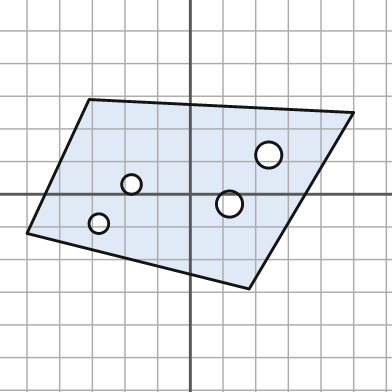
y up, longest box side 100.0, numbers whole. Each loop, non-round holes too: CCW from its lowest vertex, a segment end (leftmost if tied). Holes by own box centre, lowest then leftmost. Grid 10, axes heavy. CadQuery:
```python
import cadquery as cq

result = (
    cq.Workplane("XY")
    .moveTo(18.0, -29.0)
    .lineTo(50.0, 25.0)
    .lineTo(-31.0, 29.0)
    .lineTo(-50.0, -12.0)
    .close()
    .moveTo(-28.0, -9.0)
    .circle(3.0)
    .moveTo(12.0, -3.0)
    .circle(4.0)
    .moveTo(-18.0, 3.0)
    .circle(3.0)
    .moveTo(24.0, 12.0)
    .circle(4.0)
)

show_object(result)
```